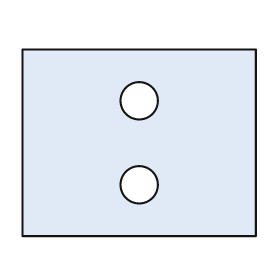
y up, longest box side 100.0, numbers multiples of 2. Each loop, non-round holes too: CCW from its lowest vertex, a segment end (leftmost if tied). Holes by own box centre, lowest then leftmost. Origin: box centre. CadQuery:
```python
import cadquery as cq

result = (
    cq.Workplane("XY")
    .moveTo(-50.0, -40.0)
    .lineTo(50.0, -40.0)
    .lineTo(50.0, 40.0)
    .lineTo(-50.0, 40.0)
    .close()
    .moveTo(0.0, -18.0)
    .circle(8.0)
    .moveTo(0.0, 18.0)
    .circle(8.0)
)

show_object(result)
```